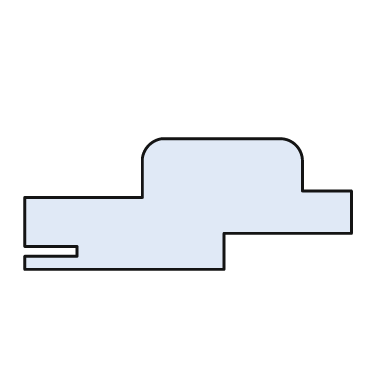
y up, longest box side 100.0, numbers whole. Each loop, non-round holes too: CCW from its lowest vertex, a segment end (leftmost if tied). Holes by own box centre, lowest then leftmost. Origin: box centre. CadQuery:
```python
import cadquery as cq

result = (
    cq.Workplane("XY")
    .moveTo(-50.0, -20.0)
    .lineTo(11.0, -20.0)
    .lineTo(11.0, -9.0)
    .lineTo(50.0, -9.0)
    .lineTo(50.0, 4.0)
    .lineTo(35.0, 4.0)
    .lineTo(35.0, 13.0)
    .threePointArc((33.0, 18.0), (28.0, 20.0))
    .lineTo(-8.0, 20.0)
    .threePointArc((-12.0, 18.0), (-14.0, 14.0))
    .lineTo(-14.0, 2.0)
    .lineTo(-50.0, 2.0)
    .lineTo(-50.0, -13.0)
    .lineTo(-34.0, -13.0)
    .lineTo(-34.0, -16.0)
    .lineTo(-50.0, -16.0)
    .close()
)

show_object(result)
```